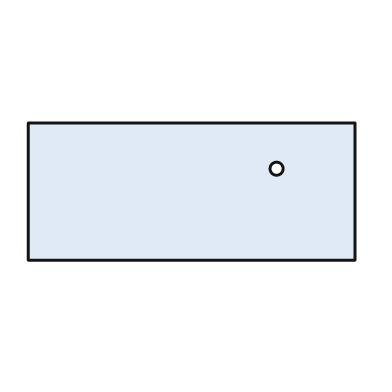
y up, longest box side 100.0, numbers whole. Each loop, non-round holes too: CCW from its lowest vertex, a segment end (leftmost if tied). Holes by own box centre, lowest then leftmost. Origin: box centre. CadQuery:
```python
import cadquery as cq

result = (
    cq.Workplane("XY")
    .moveTo(-50.0, -21.0)
    .lineTo(50.0, -21.0)
    .lineTo(50.0, 21.0)
    .lineTo(-50.0, 21.0)
    .close()
    .moveTo(26.0, 7.0)
    .circle(2.0)
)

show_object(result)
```